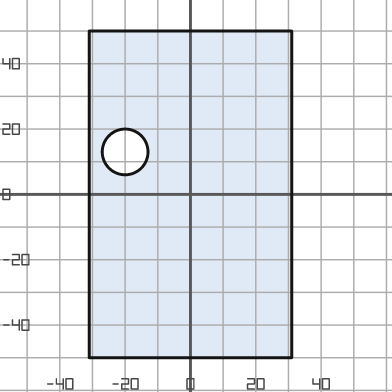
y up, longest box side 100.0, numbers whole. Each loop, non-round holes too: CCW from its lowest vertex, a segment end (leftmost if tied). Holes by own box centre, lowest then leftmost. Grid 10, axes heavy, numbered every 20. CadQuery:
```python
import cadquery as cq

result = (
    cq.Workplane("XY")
    .moveTo(-31.0, -50.0)
    .lineTo(31.0, -50.0)
    .lineTo(31.0, 50.0)
    .lineTo(-31.0, 50.0)
    .close()
    .moveTo(-20.0, 13.0)
    .circle(7.0)
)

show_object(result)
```